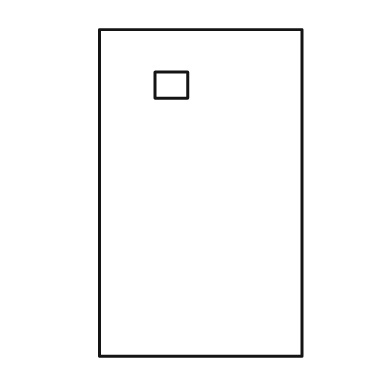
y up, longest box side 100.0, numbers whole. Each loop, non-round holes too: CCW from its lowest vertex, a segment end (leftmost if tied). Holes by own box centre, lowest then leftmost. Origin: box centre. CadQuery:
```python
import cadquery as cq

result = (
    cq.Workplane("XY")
    .moveTo(-31.0, -50.0)
    .lineTo(31.0, -50.0)
    .lineTo(31.0, 50.0)
    .lineTo(-31.0, 50.0)
    .close()
    .moveTo(-14.0, 29.0)
    .lineTo(-4.0, 29.0)
    .lineTo(-4.0, 37.0)
    .lineTo(-14.0, 37.0)
    .close()
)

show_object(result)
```